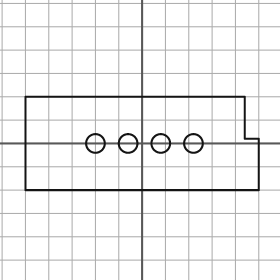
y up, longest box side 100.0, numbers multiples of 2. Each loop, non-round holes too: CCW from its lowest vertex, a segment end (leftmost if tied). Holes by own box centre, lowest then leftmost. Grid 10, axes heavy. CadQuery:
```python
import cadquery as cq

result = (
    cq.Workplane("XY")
    .moveTo(-50.0, -20.0)
    .lineTo(50.0, -20.0)
    .lineTo(50.0, 2.0)
    .lineTo(44.0, 2.0)
    .lineTo(44.0, 20.0)
    .lineTo(-50.0, 20.0)
    .close()
    .moveTo(-20.0, 0.0)
    .circle(4.0)
    .moveTo(-6.0, 0.0)
    .circle(4.0)
    .moveTo(8.0, 0.0)
    .circle(4.0)
    .moveTo(22.0, 0.0)
    .circle(4.0)
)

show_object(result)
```